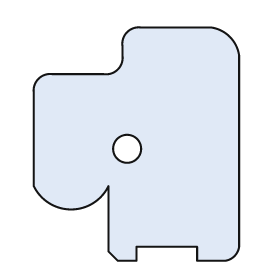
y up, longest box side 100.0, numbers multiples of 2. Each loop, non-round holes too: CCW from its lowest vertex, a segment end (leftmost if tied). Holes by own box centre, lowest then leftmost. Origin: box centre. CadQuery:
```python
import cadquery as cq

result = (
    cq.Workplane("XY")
    .moveTo(-8.0, -50.0)
    .lineTo(0.0, -50.0)
    .lineTo(0.0, -44.0)
    .lineTo(26.0, -44.0)
    .lineTo(26.0, -50.0)
    .lineTo(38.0, -50.0)
    .threePointArc((42.0, -48.0), (44.0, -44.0))
    .lineTo(44.0, 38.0)
    .threePointArc((40.0, 46.0), (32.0, 50.0))
    .lineTo(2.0, 50.0)
    .threePointArc((-4.0, 48.0), (-6.0, 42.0))
    .lineTo(-6.0, 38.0)
    .threePointArc((-8.0, 32.0), (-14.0, 30.0))
    .lineTo(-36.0, 30.0)
    .threePointArc((-42.0, 28.0), (-44.0, 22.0))
    .lineTo(-44.0, -18.0)
    .threePointArc((-28.0, -28.0), (-12.0, -18.0))
    .lineTo(-12.0, -46.0)
    .close()
    .moveTo(-4.0, -2.0)
    .circle(6.0)
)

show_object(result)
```